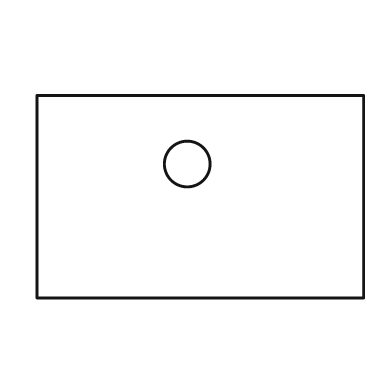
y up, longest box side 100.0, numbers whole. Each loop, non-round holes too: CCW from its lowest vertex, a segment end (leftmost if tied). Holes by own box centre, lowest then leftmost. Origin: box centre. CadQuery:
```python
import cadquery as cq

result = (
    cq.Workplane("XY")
    .moveTo(-50.0, -31.0)
    .lineTo(50.0, -31.0)
    .lineTo(50.0, 31.0)
    .lineTo(-50.0, 31.0)
    .close()
    .moveTo(-4.0, 10.0)
    .circle(7.0)
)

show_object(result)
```